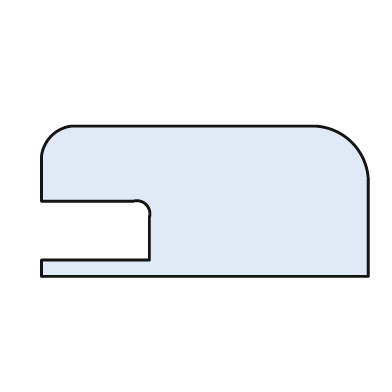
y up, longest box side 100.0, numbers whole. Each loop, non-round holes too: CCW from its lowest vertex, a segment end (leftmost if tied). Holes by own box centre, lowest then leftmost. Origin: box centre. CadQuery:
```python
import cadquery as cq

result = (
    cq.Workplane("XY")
    .moveTo(-50.0, -23.0)
    .lineTo(50.0, -23.0)
    .lineTo(50.0, 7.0)
    .threePointArc((45.0, 18.0), (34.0, 23.0))
    .lineTo(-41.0, 23.0)
    .threePointArc((-47.0, 20.0), (-50.0, 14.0))
    .lineTo(-50.0, 0.0)
    .lineTo(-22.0, 0.0)
    .threePointArc((-18.0, -1.0), (-17.0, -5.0))
    .lineTo(-17.0, -18.0)
    .lineTo(-50.0, -18.0)
    .close()
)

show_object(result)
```